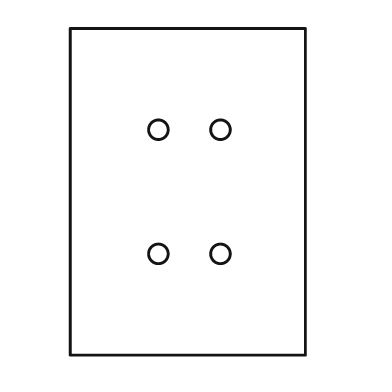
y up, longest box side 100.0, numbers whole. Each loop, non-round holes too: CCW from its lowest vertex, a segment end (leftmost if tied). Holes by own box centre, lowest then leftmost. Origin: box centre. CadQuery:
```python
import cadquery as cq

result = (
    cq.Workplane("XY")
    .moveTo(-36.0, -50.0)
    .lineTo(36.0, -50.0)
    .lineTo(36.0, 50.0)
    .lineTo(-36.0, 50.0)
    .close()
    .moveTo(-9.0, -19.0)
    .circle(3.0)
    .moveTo(10.0, -19.0)
    .circle(3.0)
    .moveTo(-9.0, 19.0)
    .circle(3.0)
    .moveTo(10.0, 19.0)
    .circle(3.0)
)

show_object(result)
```